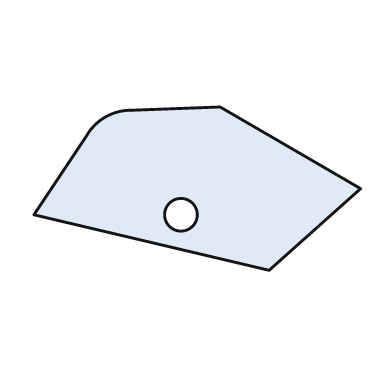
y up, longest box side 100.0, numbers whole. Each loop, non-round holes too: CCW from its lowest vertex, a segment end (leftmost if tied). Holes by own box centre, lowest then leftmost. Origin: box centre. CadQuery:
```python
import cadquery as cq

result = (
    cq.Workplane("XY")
    .moveTo(22.0, -25.0)
    .lineTo(50.0, 0.0)
    .lineTo(7.0, 25.0)
    .lineTo(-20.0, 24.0)
    .threePointArc((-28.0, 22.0), (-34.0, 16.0))
    .lineTo(-50.0, -8.0)
    .close()
    .moveTo(-5.0, -8.0)
    .circle(5.0)
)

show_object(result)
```